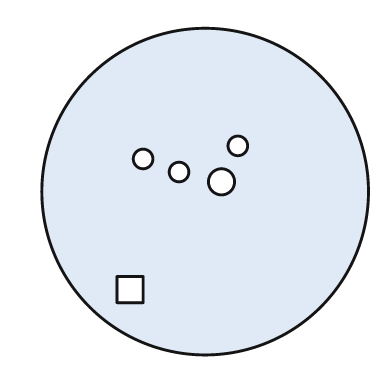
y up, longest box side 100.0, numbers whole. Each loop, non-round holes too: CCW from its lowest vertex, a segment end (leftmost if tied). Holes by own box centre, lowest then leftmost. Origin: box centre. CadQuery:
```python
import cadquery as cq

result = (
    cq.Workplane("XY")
    .moveTo(0.0, 0.0)
    .circle(50.0)
    .moveTo(-27.0, -34.0)
    .lineTo(-19.0, -34.0)
    .lineTo(-19.0, -26.0)
    .lineTo(-27.0, -26.0)
    .close()
    .moveTo(5.0, 3.0)
    .circle(4.0)
    .moveTo(-8.0, 6.0)
    .circle(3.0)
    .moveTo(-19.0, 10.0)
    .circle(3.0)
    .moveTo(10.0, 14.0)
    .circle(3.0)
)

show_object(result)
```